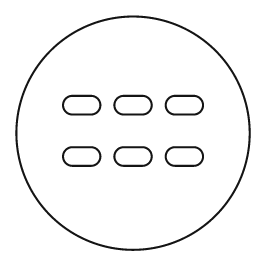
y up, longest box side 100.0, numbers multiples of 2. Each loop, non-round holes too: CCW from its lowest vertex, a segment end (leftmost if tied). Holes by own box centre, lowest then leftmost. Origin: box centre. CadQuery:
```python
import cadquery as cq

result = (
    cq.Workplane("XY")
    .moveTo(0.0, 0.0)
    .circle(50.0)
    .moveTo(-26.0, -14.0)
    .lineTo(-18.0, -14.0)
    .threePointArc((-14.0, -10.0), (-18.0, -6.0))
    .lineTo(-26.0, -6.0)
    .threePointArc((-30.0, -10.0), (-26.0, -14.0))
    .close()
    .moveTo(-4.0, -14.0)
    .lineTo(4.0, -14.0)
    .threePointArc((8.0, -10.0), (4.0, -6.0))
    .lineTo(-4.0, -6.0)
    .threePointArc((-8.0, -10.0), (-4.0, -14.0))
    .close()
    .moveTo(18.0, -14.0)
    .lineTo(26.0, -14.0)
    .threePointArc((30.0, -10.0), (26.0, -6.0))
    .lineTo(18.0, -6.0)
    .threePointArc((14.0, -10.0), (18.0, -14.0))
    .close()
    .moveTo(-26.0, 8.0)
    .lineTo(-18.0, 8.0)
    .threePointArc((-14.0, 12.0), (-18.0, 16.0))
    .lineTo(-26.0, 16.0)
    .threePointArc((-30.0, 12.0), (-26.0, 8.0))
    .close()
    .moveTo(-4.0, 8.0)
    .lineTo(4.0, 8.0)
    .threePointArc((8.0, 12.0), (4.0, 16.0))
    .lineTo(-4.0, 16.0)
    .threePointArc((-8.0, 12.0), (-4.0, 8.0))
    .close()
    .moveTo(18.0, 8.0)
    .lineTo(26.0, 8.0)
    .threePointArc((30.0, 12.0), (26.0, 16.0))
    .lineTo(18.0, 16.0)
    .threePointArc((14.0, 12.0), (18.0, 8.0))
    .close()
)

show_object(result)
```